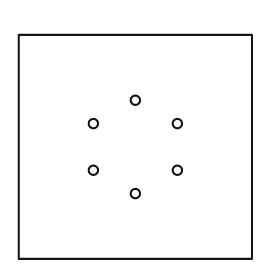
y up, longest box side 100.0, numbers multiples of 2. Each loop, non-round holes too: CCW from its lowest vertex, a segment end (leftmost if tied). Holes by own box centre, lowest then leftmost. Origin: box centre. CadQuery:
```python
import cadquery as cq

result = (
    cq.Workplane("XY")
    .moveTo(-50.0, -48.0)
    .lineTo(50.0, -48.0)
    .lineTo(50.0, 48.0)
    .lineTo(-50.0, 48.0)
    .close()
    .moveTo(0.0, -20.0)
    .circle(2.0)
    .moveTo(-18.0, -10.0)
    .circle(2.0)
    .moveTo(18.0, -10.0)
    .circle(2.0)
    .moveTo(-18.0, 10.0)
    .circle(2.0)
    .moveTo(18.0, 10.0)
    .circle(2.0)
    .moveTo(0.0, 20.0)
    .circle(2.0)
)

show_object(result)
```